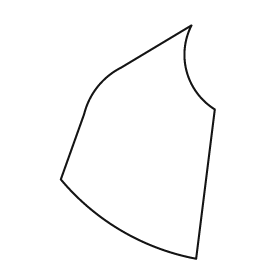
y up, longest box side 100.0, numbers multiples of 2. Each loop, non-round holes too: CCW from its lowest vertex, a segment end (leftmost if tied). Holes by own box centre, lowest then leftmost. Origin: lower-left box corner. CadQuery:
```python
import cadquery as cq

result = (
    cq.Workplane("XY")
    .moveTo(58.0, 0.0)
    .lineTo(66.0, 64.0)
    .threePointArc((54.0, 80.0), (56.0, 100.0))
    .lineTo(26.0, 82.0)
    .threePointArc((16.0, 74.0), (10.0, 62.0))
    .lineTo(0.0, 34.0)
    .threePointArc((26.0, 12.0), (58.0, 0.0))
    .close()
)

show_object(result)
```